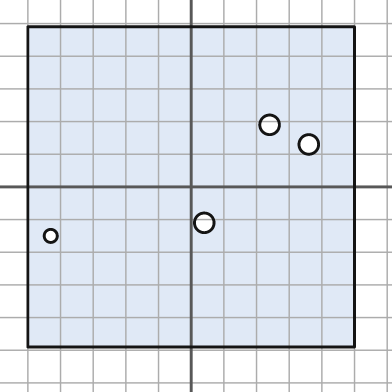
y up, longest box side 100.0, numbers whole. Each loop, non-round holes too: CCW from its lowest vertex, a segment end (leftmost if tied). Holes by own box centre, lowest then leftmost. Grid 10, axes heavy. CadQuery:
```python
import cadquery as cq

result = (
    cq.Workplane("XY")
    .moveTo(-50.0, -49.0)
    .lineTo(50.0, -49.0)
    .lineTo(50.0, 49.0)
    .lineTo(-50.0, 49.0)
    .close()
    .moveTo(-43.0, -15.0)
    .circle(2.0)
    .moveTo(4.0, -11.0)
    .circle(3.0)
    .moveTo(36.0, 13.0)
    .circle(3.0)
    .moveTo(24.0, 19.0)
    .circle(3.0)
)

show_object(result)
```